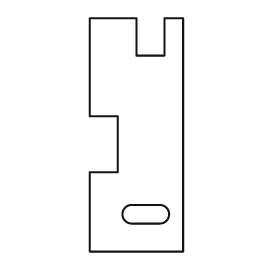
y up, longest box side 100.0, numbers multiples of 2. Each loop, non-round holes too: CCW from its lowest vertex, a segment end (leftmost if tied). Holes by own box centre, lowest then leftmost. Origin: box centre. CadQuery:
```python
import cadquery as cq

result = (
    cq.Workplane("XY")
    .moveTo(-20.0, -50.0)
    .lineTo(20.0, -50.0)
    .lineTo(20.0, 50.0)
    .lineTo(12.0, 50.0)
    .lineTo(12.0, 34.0)
    .lineTo(0.0, 34.0)
    .lineTo(0.0, 50.0)
    .lineTo(-20.0, 50.0)
    .lineTo(-20.0, 8.0)
    .lineTo(-8.0, 8.0)
    .lineTo(-8.0, -16.0)
    .lineTo(-20.0, -16.0)
    .close()
    .moveTo(-2.0, -38.0)
    .lineTo(10.0, -38.0)
    .threePointArc((14.0, -34.0), (10.0, -30.0))
    .lineTo(-2.0, -30.0)
    .threePointArc((-6.0, -34.0), (-2.0, -38.0))
    .close()
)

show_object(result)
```